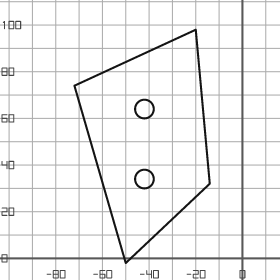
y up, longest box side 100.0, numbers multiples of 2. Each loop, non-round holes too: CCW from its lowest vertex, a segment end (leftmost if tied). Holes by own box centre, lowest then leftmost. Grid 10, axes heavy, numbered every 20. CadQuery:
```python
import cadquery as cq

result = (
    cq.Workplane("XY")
    .moveTo(-50.0, -2.0)
    .lineTo(-14.0, 32.0)
    .lineTo(-20.0, 98.0)
    .lineTo(-72.0, 74.0)
    .close()
    .moveTo(-42.0, 34.0)
    .circle(4.0)
    .moveTo(-42.0, 64.0)
    .circle(4.0)
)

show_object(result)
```